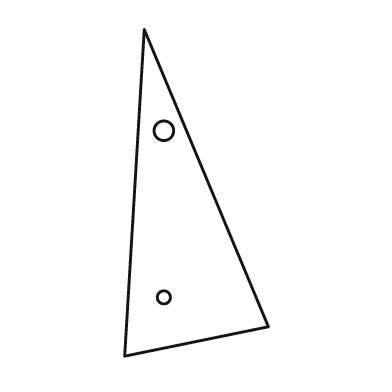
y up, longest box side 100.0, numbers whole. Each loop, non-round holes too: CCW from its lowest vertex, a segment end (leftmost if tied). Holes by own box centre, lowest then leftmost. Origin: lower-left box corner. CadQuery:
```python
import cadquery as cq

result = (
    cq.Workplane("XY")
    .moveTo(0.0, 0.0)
    .lineTo(44.0, 9.0)
    .lineTo(6.0, 100.0)
    .close()
    .moveTo(12.0, 18.0)
    .circle(2.0)
    .moveTo(12.0, 69.0)
    .circle(3.0)
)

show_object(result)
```